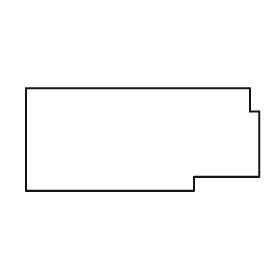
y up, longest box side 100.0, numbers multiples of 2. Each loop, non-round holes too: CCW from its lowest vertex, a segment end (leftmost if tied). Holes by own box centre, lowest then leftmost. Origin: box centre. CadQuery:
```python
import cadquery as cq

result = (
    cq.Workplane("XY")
    .moveTo(-50.0, -22.0)
    .lineTo(22.0, -22.0)
    .lineTo(22.0, -16.0)
    .lineTo(50.0, -16.0)
    .lineTo(50.0, 12.0)
    .lineTo(46.0, 12.0)
    .lineTo(46.0, 22.0)
    .lineTo(-50.0, 22.0)
    .close()
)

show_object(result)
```